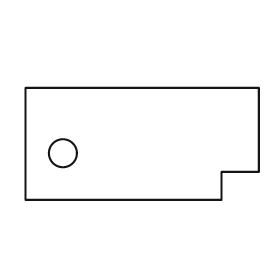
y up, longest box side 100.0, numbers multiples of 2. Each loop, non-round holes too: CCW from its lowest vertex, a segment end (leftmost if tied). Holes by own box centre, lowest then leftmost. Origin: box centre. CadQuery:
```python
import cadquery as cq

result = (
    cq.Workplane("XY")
    .moveTo(-50.0, -24.0)
    .lineTo(34.0, -24.0)
    .lineTo(34.0, -12.0)
    .lineTo(50.0, -12.0)
    .lineTo(50.0, 24.0)
    .lineTo(-50.0, 24.0)
    .close()
    .moveTo(-34.0, -4.0)
    .circle(6.0)
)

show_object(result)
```